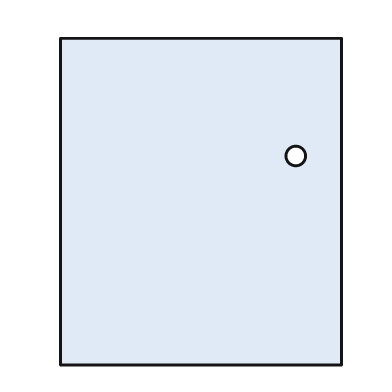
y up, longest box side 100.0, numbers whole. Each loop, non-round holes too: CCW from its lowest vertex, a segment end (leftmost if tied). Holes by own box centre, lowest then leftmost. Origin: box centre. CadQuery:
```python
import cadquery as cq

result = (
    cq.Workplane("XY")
    .moveTo(-43.0, -50.0)
    .lineTo(43.0, -50.0)
    .lineTo(43.0, 50.0)
    .lineTo(-43.0, 50.0)
    .close()
    .moveTo(29.0, 14.0)
    .circle(3.0)
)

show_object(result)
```